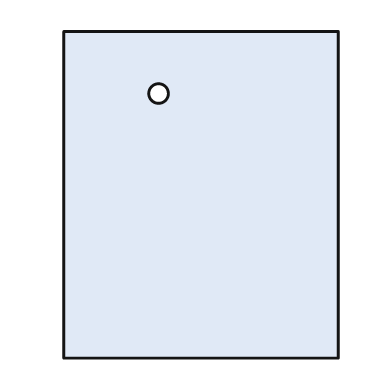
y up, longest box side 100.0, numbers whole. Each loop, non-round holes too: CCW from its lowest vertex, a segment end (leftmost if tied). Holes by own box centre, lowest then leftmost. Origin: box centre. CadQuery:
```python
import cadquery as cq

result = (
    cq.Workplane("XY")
    .moveTo(-42.0, -50.0)
    .lineTo(42.0, -50.0)
    .lineTo(42.0, 50.0)
    .lineTo(-42.0, 50.0)
    .close()
    .moveTo(-13.0, 31.0)
    .circle(3.0)
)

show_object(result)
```